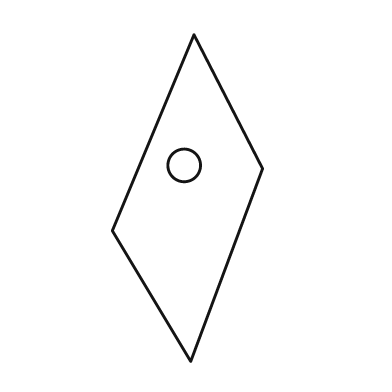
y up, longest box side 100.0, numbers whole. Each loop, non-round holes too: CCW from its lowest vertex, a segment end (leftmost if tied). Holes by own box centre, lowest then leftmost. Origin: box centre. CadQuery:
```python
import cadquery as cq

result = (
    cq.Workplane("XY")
    .moveTo(1.0, -50.0)
    .lineTo(23.0, 9.0)
    .lineTo(2.0, 50.0)
    .lineTo(-23.0, -10.0)
    .close()
    .moveTo(-1.0, 10.0)
    .circle(5.0)
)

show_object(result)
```